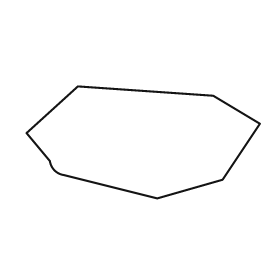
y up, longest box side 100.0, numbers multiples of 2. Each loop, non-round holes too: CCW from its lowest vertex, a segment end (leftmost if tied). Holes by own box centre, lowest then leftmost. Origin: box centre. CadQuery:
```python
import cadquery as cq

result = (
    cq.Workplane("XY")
    .moveTo(6.0, -24.0)
    .lineTo(34.0, -16.0)
    .lineTo(50.0, 8.0)
    .lineTo(30.0, 20.0)
    .lineTo(-28.0, 24.0)
    .lineTo(-50.0, 4.0)
    .lineTo(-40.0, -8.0)
    .threePointArc((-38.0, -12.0), (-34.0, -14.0))
    .close()
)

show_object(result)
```